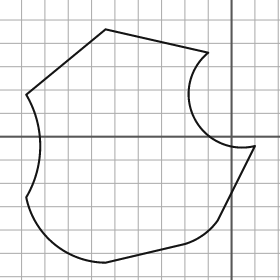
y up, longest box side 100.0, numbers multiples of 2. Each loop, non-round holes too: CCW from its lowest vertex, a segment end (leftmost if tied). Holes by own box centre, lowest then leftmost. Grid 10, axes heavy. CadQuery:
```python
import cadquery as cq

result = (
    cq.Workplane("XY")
    .moveTo(-54.0, -54.0)
    .lineTo(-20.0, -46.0)
    .threePointArc((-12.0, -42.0), (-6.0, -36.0))
    .lineTo(10.0, -4.0)
    .threePointArc((-16.0, 8.0), (-10.0, 36.0))
    .lineTo(-54.0, 46.0)
    .lineTo(-88.0, 18.0)
    .threePointArc((-82.0, -4.0), (-88.0, -26.0))
    .threePointArc((-76.0, -46.0), (-54.0, -54.0))
    .close()
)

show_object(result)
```